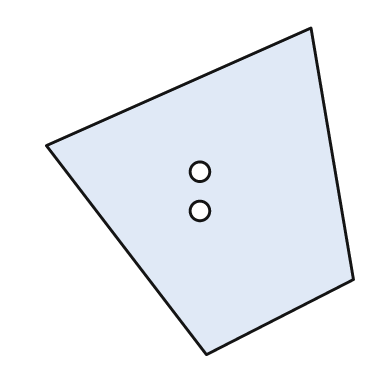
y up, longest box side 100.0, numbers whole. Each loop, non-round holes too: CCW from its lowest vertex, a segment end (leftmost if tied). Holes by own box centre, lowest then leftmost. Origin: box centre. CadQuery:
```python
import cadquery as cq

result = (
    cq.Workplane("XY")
    .moveTo(2.0, -50.0)
    .lineTo(47.0, -27.0)
    .lineTo(34.0, 50.0)
    .lineTo(-47.0, 14.0)
    .close()
    .moveTo(0.0, -6.0)
    .circle(3.0)
    .moveTo(0.0, 6.0)
    .circle(3.0)
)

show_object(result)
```